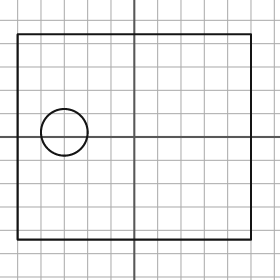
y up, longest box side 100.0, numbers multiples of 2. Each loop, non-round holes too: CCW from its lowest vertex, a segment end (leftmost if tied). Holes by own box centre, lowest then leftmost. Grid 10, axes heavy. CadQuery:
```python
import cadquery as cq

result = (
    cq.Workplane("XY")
    .moveTo(-50.0, -44.0)
    .lineTo(50.0, -44.0)
    .lineTo(50.0, 44.0)
    .lineTo(-50.0, 44.0)
    .close()
    .moveTo(-30.0, 2.0)
    .circle(10.0)
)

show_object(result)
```